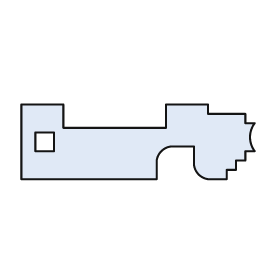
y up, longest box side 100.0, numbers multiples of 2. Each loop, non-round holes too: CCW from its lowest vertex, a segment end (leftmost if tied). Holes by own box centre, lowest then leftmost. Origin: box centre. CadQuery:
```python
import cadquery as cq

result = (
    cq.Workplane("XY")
    .moveTo(-50.0, -16.0)
    .lineTo(8.0, -16.0)
    .lineTo(8.0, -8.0)
    .threePointArc((10.0, -4.0), (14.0, -2.0))
    .lineTo(24.0, -2.0)
    .lineTo(24.0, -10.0)
    .threePointArc((26.0, -14.0), (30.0, -16.0))
    .lineTo(38.0, -16.0)
    .lineTo(38.0, -12.0)
    .lineTo(42.0, -12.0)
    .lineTo(42.0, -8.0)
    .lineTo(46.0, -8.0)
    .lineTo(46.0, -4.0)
    .lineTo(50.0, -4.0)
    .threePointArc((48.0, 2.0), (50.0, 8.0))
    .lineTo(46.0, 8.0)
    .lineTo(46.0, 12.0)
    .lineTo(30.0, 12.0)
    .lineTo(30.0, 16.0)
    .lineTo(12.0, 16.0)
    .lineTo(12.0, 6.0)
    .lineTo(-32.0, 6.0)
    .lineTo(-32.0, 16.0)
    .lineTo(-50.0, 16.0)
    .close()
    .moveTo(-44.0, -4.0)
    .lineTo(-36.0, -4.0)
    .lineTo(-36.0, 4.0)
    .lineTo(-44.0, 4.0)
    .close()
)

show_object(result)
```